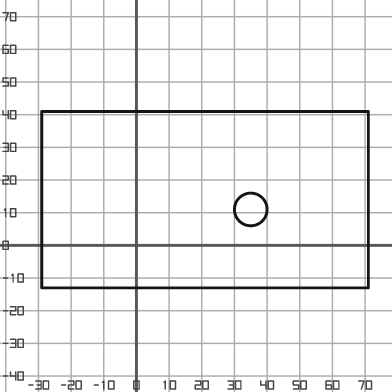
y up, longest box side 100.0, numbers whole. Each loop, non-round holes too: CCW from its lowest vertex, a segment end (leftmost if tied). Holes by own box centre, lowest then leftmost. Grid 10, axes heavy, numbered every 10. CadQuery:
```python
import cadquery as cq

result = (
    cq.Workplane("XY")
    .moveTo(-29.0, -13.0)
    .lineTo(71.0, -13.0)
    .lineTo(71.0, 41.0)
    .lineTo(-29.0, 41.0)
    .close()
    .moveTo(35.0, 11.0)
    .circle(5.0)
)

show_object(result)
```